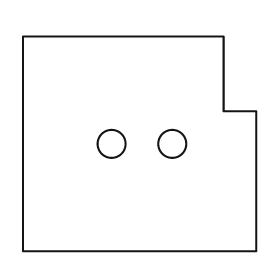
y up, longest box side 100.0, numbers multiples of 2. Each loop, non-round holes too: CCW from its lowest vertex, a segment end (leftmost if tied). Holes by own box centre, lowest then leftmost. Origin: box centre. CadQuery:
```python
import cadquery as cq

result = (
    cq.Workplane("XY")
    .moveTo(-50.0, -46.0)
    .lineTo(50.0, -46.0)
    .lineTo(50.0, 14.0)
    .lineTo(36.0, 14.0)
    .lineTo(36.0, 46.0)
    .lineTo(-50.0, 46.0)
    .close()
    .moveTo(-12.0, 0.0)
    .circle(6.0)
    .moveTo(14.0, 0.0)
    .circle(6.0)
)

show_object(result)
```